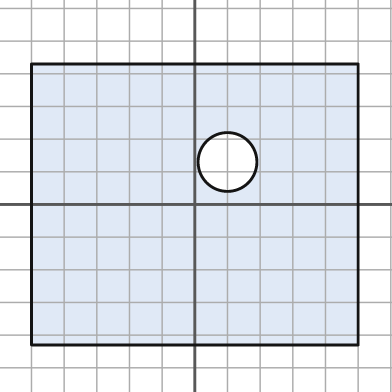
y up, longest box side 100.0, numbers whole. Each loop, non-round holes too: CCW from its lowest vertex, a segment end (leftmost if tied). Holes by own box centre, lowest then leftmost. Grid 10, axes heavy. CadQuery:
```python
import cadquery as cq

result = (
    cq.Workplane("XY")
    .moveTo(-50.0, -43.0)
    .lineTo(50.0, -43.0)
    .lineTo(50.0, 43.0)
    .lineTo(-50.0, 43.0)
    .close()
    .moveTo(10.0, 13.0)
    .circle(9.0)
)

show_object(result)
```